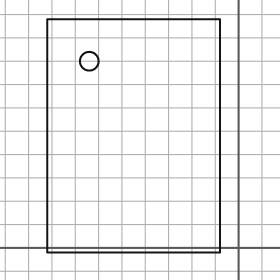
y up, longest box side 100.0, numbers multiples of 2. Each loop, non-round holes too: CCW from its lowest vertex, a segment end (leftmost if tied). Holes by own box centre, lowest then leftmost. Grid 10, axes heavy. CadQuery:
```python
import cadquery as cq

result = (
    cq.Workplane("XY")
    .moveTo(-82.0, -2.0)
    .lineTo(-8.0, -2.0)
    .lineTo(-8.0, 98.0)
    .lineTo(-82.0, 98.0)
    .close()
    .moveTo(-64.0, 80.0)
    .circle(4.0)
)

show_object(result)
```